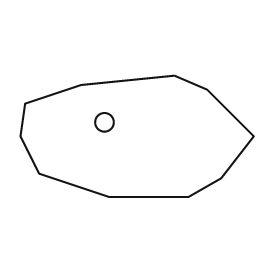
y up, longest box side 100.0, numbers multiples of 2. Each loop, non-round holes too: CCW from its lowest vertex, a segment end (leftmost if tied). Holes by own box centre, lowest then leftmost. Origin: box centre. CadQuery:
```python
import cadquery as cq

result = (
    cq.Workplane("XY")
    .moveTo(-12.0, -26.0)
    .lineTo(22.0, -26.0)
    .lineTo(36.0, -18.0)
    .lineTo(50.0, 0.0)
    .lineTo(30.0, 20.0)
    .lineTo(16.0, 26.0)
    .lineTo(-24.0, 22.0)
    .lineTo(-48.0, 14.0)
    .lineTo(-50.0, 0.0)
    .lineTo(-42.0, -16.0)
    .close()
    .moveTo(-14.0, 6.0)
    .circle(4.0)
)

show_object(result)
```